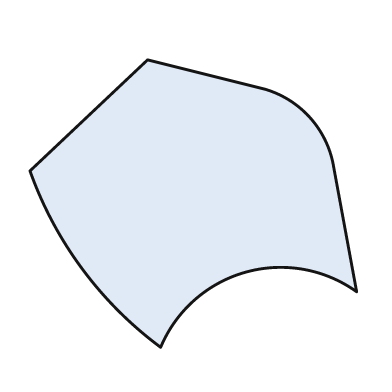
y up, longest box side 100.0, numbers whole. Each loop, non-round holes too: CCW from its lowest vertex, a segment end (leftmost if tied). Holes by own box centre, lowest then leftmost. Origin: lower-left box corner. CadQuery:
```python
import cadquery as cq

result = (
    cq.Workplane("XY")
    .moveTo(40.0, 0.0)
    .threePointArc((66.0, 23.0), (100.0, 17.0))
    .lineTo(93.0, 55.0)
    .threePointArc((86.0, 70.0), (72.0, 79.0))
    .lineTo(36.0, 88.0)
    .lineTo(0.0, 54.0)
    .threePointArc((16.0, 24.0), (40.0, 0.0))
    .close()
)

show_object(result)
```